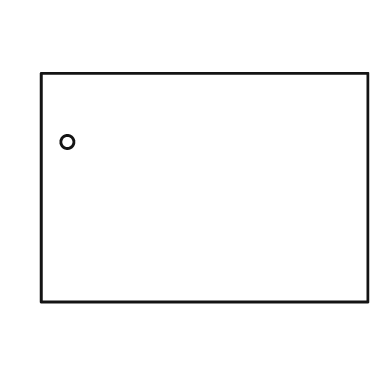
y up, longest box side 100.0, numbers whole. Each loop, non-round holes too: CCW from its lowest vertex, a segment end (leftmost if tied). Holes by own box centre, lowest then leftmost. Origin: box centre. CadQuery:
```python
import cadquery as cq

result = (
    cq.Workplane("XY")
    .moveTo(-50.0, -35.0)
    .lineTo(50.0, -35.0)
    .lineTo(50.0, 35.0)
    .lineTo(-50.0, 35.0)
    .close()
    .moveTo(-42.0, 14.0)
    .circle(2.0)
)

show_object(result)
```